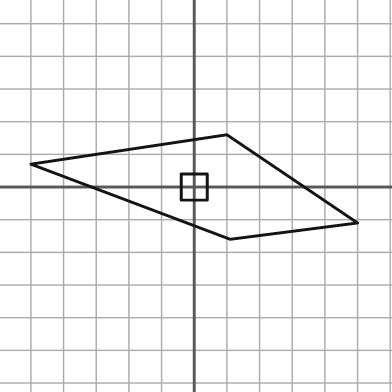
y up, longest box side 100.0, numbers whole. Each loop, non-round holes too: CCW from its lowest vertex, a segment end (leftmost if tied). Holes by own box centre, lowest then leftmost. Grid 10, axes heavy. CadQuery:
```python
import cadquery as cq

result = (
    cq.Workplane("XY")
    .moveTo(11.0, -16.0)
    .lineTo(50.0, -11.0)
    .lineTo(10.0, 16.0)
    .lineTo(-50.0, 7.0)
    .close()
    .moveTo(-4.0, -4.0)
    .lineTo(4.0, -4.0)
    .lineTo(4.0, 4.0)
    .lineTo(-4.0, 4.0)
    .close()
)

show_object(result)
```